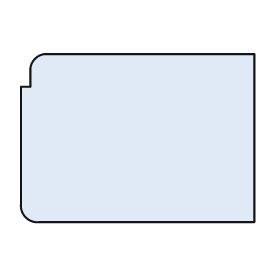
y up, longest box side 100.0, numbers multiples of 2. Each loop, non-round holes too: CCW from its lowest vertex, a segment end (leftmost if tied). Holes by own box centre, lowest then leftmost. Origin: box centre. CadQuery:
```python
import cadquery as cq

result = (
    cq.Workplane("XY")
    .moveTo(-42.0, -36.0)
    .lineTo(50.0, -36.0)
    .lineTo(50.0, 36.0)
    .lineTo(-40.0, 36.0)
    .threePointArc((-44.0, 34.0), (-46.0, 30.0))
    .lineTo(-46.0, 22.0)
    .lineTo(-50.0, 22.0)
    .lineTo(-50.0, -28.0)
    .threePointArc((-48.0, -34.0), (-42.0, -36.0))
    .close()
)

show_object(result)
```